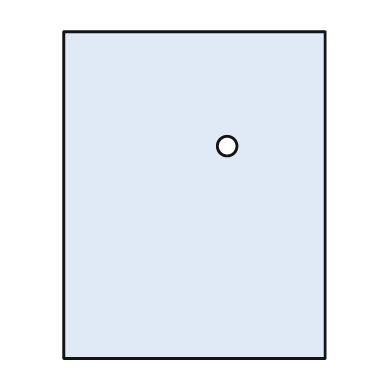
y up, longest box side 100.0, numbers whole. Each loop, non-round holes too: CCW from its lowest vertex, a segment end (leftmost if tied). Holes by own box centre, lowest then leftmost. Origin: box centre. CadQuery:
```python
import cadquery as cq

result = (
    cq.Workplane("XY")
    .moveTo(-40.0, -50.0)
    .lineTo(40.0, -50.0)
    .lineTo(40.0, 50.0)
    .lineTo(-40.0, 50.0)
    .close()
    .moveTo(10.0, 15.0)
    .circle(3.0)
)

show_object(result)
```